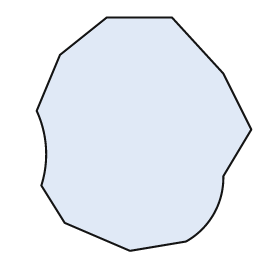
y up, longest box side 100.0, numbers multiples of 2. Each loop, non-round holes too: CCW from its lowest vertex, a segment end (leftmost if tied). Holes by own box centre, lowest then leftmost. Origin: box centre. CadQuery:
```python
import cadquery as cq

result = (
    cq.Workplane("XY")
    .moveTo(-6.0, -50.0)
    .lineTo(18.0, -46.0)
    .threePointArc((30.0, -34.0), (34.0, -18.0))
    .lineTo(46.0, 2.0)
    .lineTo(34.0, 26.0)
    .lineTo(12.0, 50.0)
    .lineTo(-16.0, 50.0)
    .lineTo(-36.0, 34.0)
    .lineTo(-46.0, 10.0)
    .threePointArc((-42.0, -6.0), (-44.0, -22.0))
    .lineTo(-34.0, -38.0)
    .close()
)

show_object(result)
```